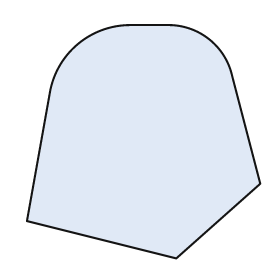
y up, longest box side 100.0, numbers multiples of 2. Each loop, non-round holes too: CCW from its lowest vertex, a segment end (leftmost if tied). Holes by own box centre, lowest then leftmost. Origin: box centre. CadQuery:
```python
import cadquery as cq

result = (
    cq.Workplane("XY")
    .moveTo(14.0, -50.0)
    .lineTo(50.0, -18.0)
    .lineTo(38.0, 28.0)
    .threePointArc((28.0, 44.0), (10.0, 50.0))
    .lineTo(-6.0, 50.0)
    .threePointArc((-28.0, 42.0), (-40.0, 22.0))
    .lineTo(-50.0, -34.0)
    .close()
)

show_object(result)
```